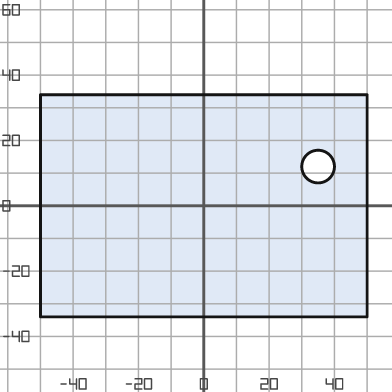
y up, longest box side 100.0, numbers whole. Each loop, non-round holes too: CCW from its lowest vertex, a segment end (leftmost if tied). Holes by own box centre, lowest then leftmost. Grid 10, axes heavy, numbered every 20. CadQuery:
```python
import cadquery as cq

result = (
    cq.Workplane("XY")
    .moveTo(-50.0, -34.0)
    .lineTo(50.0, -34.0)
    .lineTo(50.0, 34.0)
    .lineTo(-50.0, 34.0)
    .close()
    .moveTo(35.0, 12.0)
    .circle(5.0)
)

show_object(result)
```